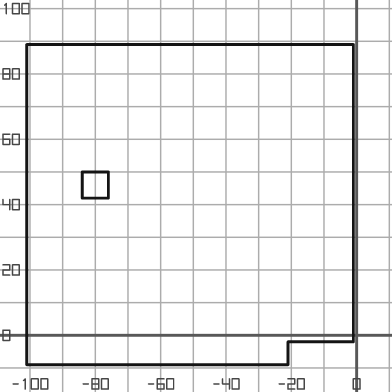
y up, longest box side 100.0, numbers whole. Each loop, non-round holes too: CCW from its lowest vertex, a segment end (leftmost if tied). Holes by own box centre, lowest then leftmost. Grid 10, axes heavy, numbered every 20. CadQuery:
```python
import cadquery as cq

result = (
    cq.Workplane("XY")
    .moveTo(-101.0, -9.0)
    .lineTo(-21.0, -9.0)
    .lineTo(-21.0, -2.0)
    .lineTo(-1.0, -2.0)
    .lineTo(-1.0, 89.0)
    .lineTo(-101.0, 89.0)
    .close()
    .moveTo(-84.0, 42.0)
    .lineTo(-76.0, 42.0)
    .lineTo(-76.0, 50.0)
    .lineTo(-84.0, 50.0)
    .close()
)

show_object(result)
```